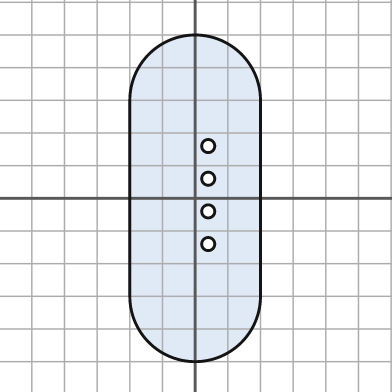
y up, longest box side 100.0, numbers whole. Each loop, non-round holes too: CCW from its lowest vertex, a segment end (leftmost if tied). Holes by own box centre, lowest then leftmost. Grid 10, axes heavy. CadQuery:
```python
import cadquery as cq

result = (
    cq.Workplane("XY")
    .moveTo(-20.0, -30.0)
    .threePointArc((0.0, -50.0), (20.0, -30.0))
    .lineTo(20.0, 30.0)
    .threePointArc((0.0, 50.0), (-20.0, 30.0))
    .close()
    .moveTo(4.0, -14.0)
    .circle(2.0)
    .moveTo(4.0, -4.0)
    .circle(2.0)
    .moveTo(4.0, 6.0)
    .circle(2.0)
    .moveTo(4.0, 16.0)
    .circle(2.0)
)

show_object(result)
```